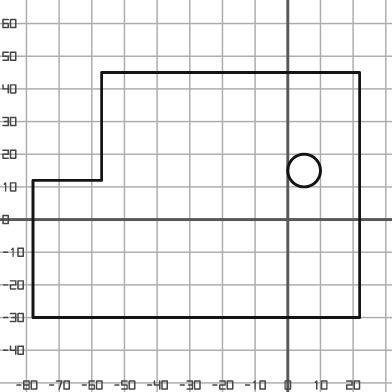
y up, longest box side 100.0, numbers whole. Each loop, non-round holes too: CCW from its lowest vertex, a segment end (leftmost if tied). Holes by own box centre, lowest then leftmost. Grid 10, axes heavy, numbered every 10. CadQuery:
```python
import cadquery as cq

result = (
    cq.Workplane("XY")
    .moveTo(-78.0, -30.0)
    .lineTo(22.0, -30.0)
    .lineTo(22.0, 45.0)
    .lineTo(-57.0, 45.0)
    .lineTo(-57.0, 12.0)
    .lineTo(-78.0, 12.0)
    .close()
    .moveTo(5.0, 15.0)
    .circle(5.0)
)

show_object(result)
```